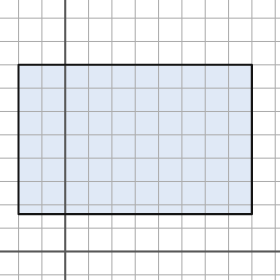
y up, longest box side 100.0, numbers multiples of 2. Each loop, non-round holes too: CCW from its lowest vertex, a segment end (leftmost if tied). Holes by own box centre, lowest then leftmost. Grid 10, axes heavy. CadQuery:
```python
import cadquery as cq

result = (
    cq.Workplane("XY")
    .moveTo(-20.0, 16.0)
    .lineTo(80.0, 16.0)
    .lineTo(80.0, 80.0)
    .lineTo(-20.0, 80.0)
    .close()
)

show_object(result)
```